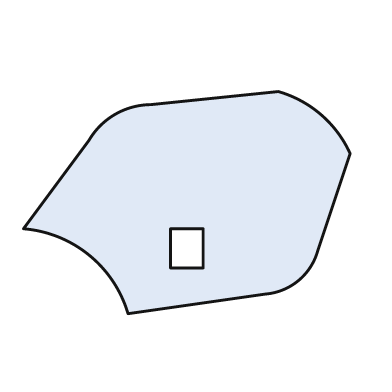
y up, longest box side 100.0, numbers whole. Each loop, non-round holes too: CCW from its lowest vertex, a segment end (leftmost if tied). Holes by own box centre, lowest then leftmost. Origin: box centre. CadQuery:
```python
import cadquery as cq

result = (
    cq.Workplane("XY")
    .moveTo(-18.0, -34.0)
    .lineTo(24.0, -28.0)
    .threePointArc((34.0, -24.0), (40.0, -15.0))
    .lineTo(50.0, 15.0)
    .threePointArc((41.0, 27.0), (28.0, 34.0))
    .lineTo(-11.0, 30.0)
    .threePointArc((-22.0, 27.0), (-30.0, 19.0))
    .lineTo(-50.0, -8.0)
    .threePointArc((-30.0, -16.0), (-18.0, -34.0))
    .close()
    .moveTo(-5.0, -20.0)
    .lineTo(5.0, -20.0)
    .lineTo(5.0, -8.0)
    .lineTo(-5.0, -8.0)
    .close()
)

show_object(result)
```